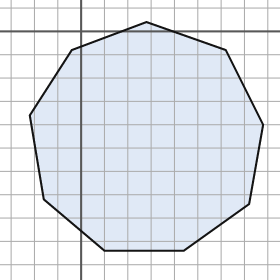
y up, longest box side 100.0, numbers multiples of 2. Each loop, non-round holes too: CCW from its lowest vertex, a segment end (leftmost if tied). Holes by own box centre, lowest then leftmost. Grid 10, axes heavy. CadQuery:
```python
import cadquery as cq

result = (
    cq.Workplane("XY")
    .moveTo(10.0, -94.0)
    .lineTo(44.0, -94.0)
    .lineTo(72.0, -74.0)
    .lineTo(78.0, -40.0)
    .lineTo(62.0, -8.0)
    .lineTo(28.0, 4.0)
    .lineTo(-4.0, -8.0)
    .lineTo(-22.0, -36.0)
    .lineTo(-16.0, -72.0)
    .close()
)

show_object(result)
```